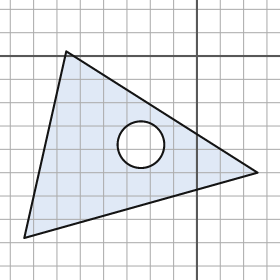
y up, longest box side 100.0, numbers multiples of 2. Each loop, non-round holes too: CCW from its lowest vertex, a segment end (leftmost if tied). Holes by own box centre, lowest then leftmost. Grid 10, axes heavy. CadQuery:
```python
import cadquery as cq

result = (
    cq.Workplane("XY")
    .moveTo(-74.0, -78.0)
    .lineTo(26.0, -50.0)
    .lineTo(-56.0, 2.0)
    .close()
    .moveTo(-24.0, -38.0)
    .circle(10.0)
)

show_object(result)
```